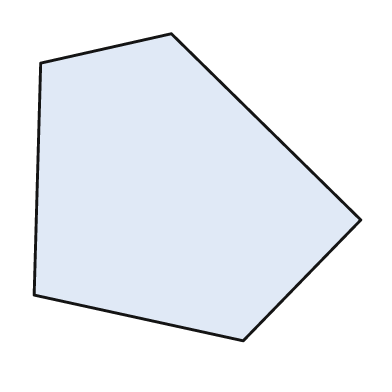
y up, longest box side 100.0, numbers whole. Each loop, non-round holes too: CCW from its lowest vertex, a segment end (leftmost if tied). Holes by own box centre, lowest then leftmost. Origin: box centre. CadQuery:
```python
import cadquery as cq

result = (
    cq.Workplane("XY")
    .moveTo(14.0, -47.0)
    .lineTo(50.0, -10.0)
    .lineTo(-8.0, 47.0)
    .lineTo(-48.0, 38.0)
    .lineTo(-50.0, -33.0)
    .close()
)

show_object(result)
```